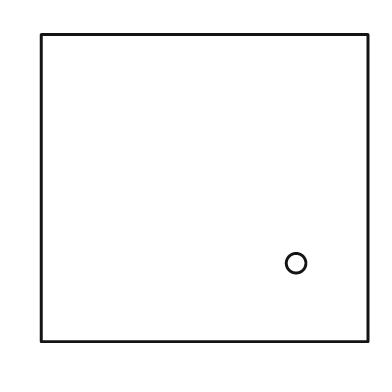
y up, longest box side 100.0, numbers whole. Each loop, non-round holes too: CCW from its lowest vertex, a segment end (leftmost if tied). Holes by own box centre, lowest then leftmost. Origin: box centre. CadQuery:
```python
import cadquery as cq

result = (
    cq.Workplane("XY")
    .moveTo(-50.0, -47.0)
    .lineTo(50.0, -47.0)
    .lineTo(50.0, 47.0)
    .lineTo(-50.0, 47.0)
    .close()
    .moveTo(28.0, -23.0)
    .circle(3.0)
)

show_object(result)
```